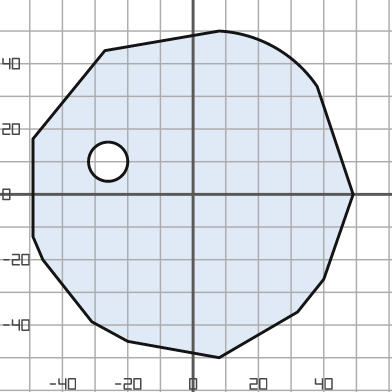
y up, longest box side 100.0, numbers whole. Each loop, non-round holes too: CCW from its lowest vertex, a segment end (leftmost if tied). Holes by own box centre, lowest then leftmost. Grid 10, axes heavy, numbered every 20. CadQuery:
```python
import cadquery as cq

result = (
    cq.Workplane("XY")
    .moveTo(8.0, -50.0)
    .lineTo(32.0, -36.0)
    .lineTo(40.0, -26.0)
    .lineTo(49.0, 0.0)
    .lineTo(38.0, 33.0)
    .threePointArc((25.0, 45.0), (8.0, 50.0))
    .lineTo(-27.0, 44.0)
    .lineTo(-49.0, 17.0)
    .lineTo(-49.0, -13.0)
    .lineTo(-46.0, -20.0)
    .lineTo(-31.0, -39.0)
    .lineTo(-20.0, -45.0)
    .close()
    .moveTo(-26.0, 10.0)
    .circle(6.0)
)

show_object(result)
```